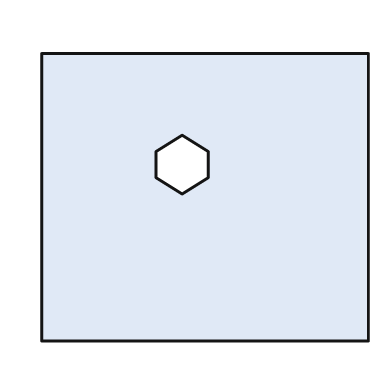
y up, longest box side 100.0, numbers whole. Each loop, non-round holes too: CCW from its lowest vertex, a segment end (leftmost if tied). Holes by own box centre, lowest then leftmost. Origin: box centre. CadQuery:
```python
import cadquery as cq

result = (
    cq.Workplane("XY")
    .moveTo(-50.0, -44.0)
    .lineTo(50.0, -44.0)
    .lineTo(50.0, 44.0)
    .lineTo(-50.0, 44.0)
    .close()
    .moveTo(-7.0, 1.0)
    .lineTo(1.0, 6.0)
    .lineTo(1.0, 14.0)
    .lineTo(-7.0, 19.0)
    .lineTo(-15.0, 14.0)
    .lineTo(-15.0, 6.0)
    .close()
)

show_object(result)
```